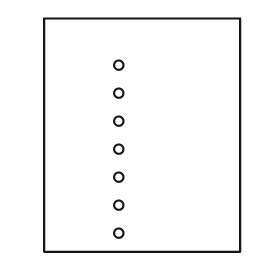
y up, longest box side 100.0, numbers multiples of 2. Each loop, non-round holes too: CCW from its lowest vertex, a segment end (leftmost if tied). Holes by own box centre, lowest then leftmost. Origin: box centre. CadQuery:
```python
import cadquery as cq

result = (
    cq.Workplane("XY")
    .moveTo(-42.0, -50.0)
    .lineTo(42.0, -50.0)
    .lineTo(42.0, 50.0)
    .lineTo(-42.0, 50.0)
    .close()
    .moveTo(-10.0, -42.0)
    .circle(2.0)
    .moveTo(-10.0, -30.0)
    .circle(2.0)
    .moveTo(-10.0, -18.0)
    .circle(2.0)
    .moveTo(-10.0, -6.0)
    .circle(2.0)
    .moveTo(-10.0, 6.0)
    .circle(2.0)
    .moveTo(-10.0, 18.0)
    .circle(2.0)
    .moveTo(-10.0, 30.0)
    .circle(2.0)
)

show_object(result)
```